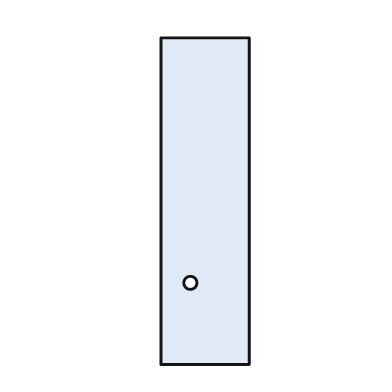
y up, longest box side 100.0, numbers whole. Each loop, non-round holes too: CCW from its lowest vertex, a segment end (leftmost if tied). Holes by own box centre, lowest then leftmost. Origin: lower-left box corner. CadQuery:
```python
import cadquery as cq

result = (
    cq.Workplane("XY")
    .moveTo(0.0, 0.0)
    .lineTo(27.0, 0.0)
    .lineTo(27.0, 100.0)
    .lineTo(0.0, 100.0)
    .close()
    .moveTo(9.0, 25.0)
    .circle(2.0)
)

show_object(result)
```